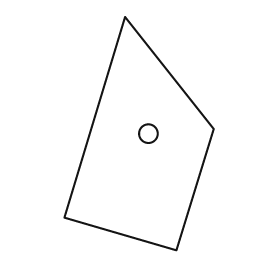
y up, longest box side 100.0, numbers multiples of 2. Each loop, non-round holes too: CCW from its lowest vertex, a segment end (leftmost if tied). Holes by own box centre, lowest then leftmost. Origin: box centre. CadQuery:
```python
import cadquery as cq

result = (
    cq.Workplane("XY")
    .moveTo(16.0, -50.0)
    .lineTo(32.0, 2.0)
    .lineTo(-6.0, 50.0)
    .lineTo(-32.0, -36.0)
    .close()
    .moveTo(4.0, 0.0)
    .circle(4.0)
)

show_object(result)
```